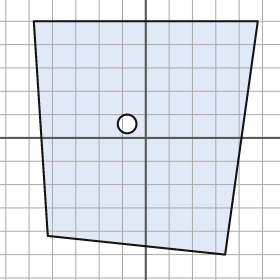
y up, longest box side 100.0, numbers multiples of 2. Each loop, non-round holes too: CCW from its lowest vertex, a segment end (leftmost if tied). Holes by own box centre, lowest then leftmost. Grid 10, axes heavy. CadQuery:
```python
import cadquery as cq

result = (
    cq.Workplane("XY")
    .moveTo(34.0, -50.0)
    .lineTo(48.0, 50.0)
    .lineTo(-48.0, 50.0)
    .lineTo(-42.0, -42.0)
    .close()
    .moveTo(-8.0, 6.0)
    .circle(4.0)
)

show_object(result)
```